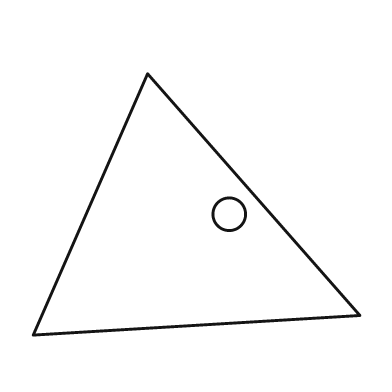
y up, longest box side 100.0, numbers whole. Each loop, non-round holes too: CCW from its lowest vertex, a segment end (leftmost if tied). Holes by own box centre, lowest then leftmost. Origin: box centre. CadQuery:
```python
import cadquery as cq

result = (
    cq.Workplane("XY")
    .moveTo(-50.0, -40.0)
    .lineTo(50.0, -34.0)
    .lineTo(-15.0, 40.0)
    .close()
    .moveTo(10.0, -3.0)
    .circle(5.0)
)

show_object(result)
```